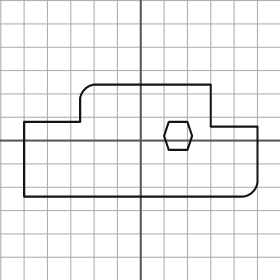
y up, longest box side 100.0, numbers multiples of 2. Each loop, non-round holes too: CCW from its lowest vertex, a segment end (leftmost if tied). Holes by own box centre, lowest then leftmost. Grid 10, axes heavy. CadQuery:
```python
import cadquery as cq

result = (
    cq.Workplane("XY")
    .moveTo(-50.0, -24.0)
    .lineTo(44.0, -24.0)
    .threePointArc((48.0, -22.0), (50.0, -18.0))
    .lineTo(50.0, 6.0)
    .lineTo(30.0, 6.0)
    .lineTo(30.0, 24.0)
    .lineTo(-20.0, 24.0)
    .threePointArc((-24.0, 22.0), (-26.0, 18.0))
    .lineTo(-26.0, 8.0)
    .lineTo(-50.0, 8.0)
    .close()
    .moveTo(12.0, -4.0)
    .lineTo(20.0, -4.0)
    .lineTo(22.0, 2.0)
    .lineTo(20.0, 8.0)
    .lineTo(12.0, 8.0)
    .lineTo(10.0, 2.0)
    .close()
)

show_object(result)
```